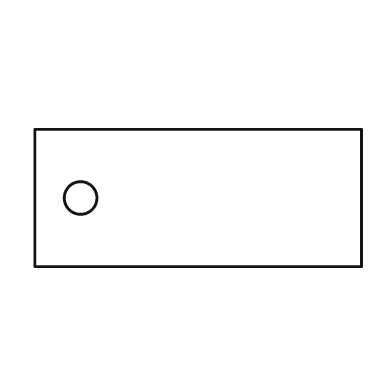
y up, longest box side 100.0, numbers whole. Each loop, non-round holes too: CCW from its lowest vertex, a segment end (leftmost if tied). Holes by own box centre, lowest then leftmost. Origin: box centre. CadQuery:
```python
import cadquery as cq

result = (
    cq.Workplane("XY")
    .moveTo(-50.0, -21.0)
    .lineTo(50.0, -21.0)
    .lineTo(50.0, 21.0)
    .lineTo(-50.0, 21.0)
    .close()
    .moveTo(-36.0, 0.0)
    .circle(5.0)
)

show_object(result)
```